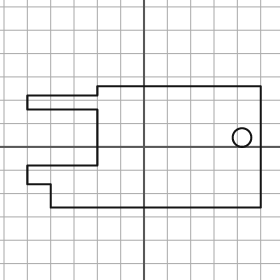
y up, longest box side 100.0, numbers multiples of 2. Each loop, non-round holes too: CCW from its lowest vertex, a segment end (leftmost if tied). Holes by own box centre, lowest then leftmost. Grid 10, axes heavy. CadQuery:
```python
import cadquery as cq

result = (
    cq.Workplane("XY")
    .moveTo(-40.0, -26.0)
    .lineTo(50.0, -26.0)
    .lineTo(50.0, 26.0)
    .lineTo(-20.0, 26.0)
    .lineTo(-20.0, 22.0)
    .lineTo(-50.0, 22.0)
    .lineTo(-50.0, 16.0)
    .lineTo(-20.0, 16.0)
    .lineTo(-20.0, -8.0)
    .lineTo(-50.0, -8.0)
    .lineTo(-50.0, -16.0)
    .lineTo(-40.0, -16.0)
    .close()
    .moveTo(42.0, 4.0)
    .circle(4.0)
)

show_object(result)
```